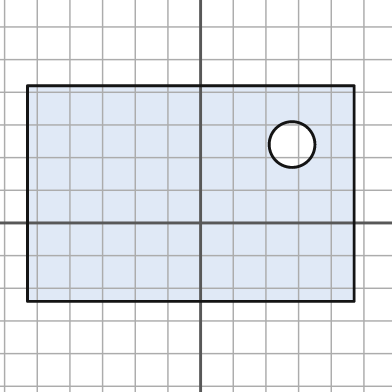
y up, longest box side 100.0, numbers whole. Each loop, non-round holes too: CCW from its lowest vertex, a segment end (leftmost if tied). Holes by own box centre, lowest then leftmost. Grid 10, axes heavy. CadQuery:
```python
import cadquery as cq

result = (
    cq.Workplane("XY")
    .moveTo(-53.0, -24.0)
    .lineTo(47.0, -24.0)
    .lineTo(47.0, 42.0)
    .lineTo(-53.0, 42.0)
    .close()
    .moveTo(28.0, 24.0)
    .circle(7.0)
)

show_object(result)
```